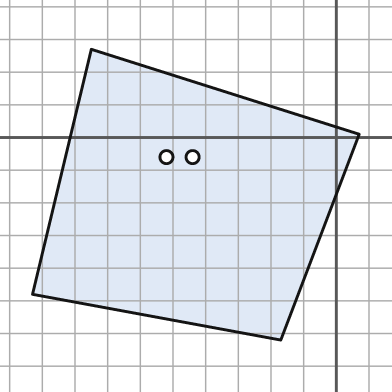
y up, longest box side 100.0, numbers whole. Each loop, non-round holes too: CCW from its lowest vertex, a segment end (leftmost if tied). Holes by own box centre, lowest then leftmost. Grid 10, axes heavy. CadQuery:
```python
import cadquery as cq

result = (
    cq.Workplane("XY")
    .moveTo(-17.0, -62.0)
    .lineTo(7.0, 1.0)
    .lineTo(-75.0, 27.0)
    .lineTo(-93.0, -48.0)
    .close()
    .moveTo(-52.0, -6.0)
    .circle(2.0)
    .moveTo(-44.0, -6.0)
    .circle(2.0)
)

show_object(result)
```